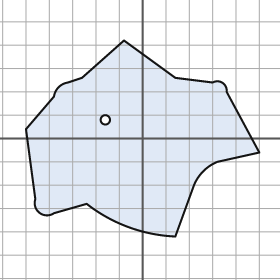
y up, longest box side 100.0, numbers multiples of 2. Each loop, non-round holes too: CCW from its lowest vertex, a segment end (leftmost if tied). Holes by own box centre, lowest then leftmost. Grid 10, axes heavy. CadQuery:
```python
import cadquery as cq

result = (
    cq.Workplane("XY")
    .moveTo(14.0, -42.0)
    .lineTo(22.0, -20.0)
    .threePointArc((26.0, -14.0), (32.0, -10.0))
    .lineTo(50.0, -6.0)
    .lineTo(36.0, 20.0)
    .threePointArc((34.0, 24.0), (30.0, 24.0))
    .lineTo(14.0, 26.0)
    .lineTo(-8.0, 42.0)
    .lineTo(-26.0, 26.0)
    .lineTo(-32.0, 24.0)
    .threePointArc((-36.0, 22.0), (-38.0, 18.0))
    .lineTo(-50.0, 4.0)
    .lineTo(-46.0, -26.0)
    .threePointArc((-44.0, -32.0), (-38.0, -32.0))
    .lineTo(-24.0, -28.0)
    .threePointArc((-6.0, -38.0), (14.0, -42.0))
    .close()
    .moveTo(-16.0, 8.0)
    .circle(2.0)
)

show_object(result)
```